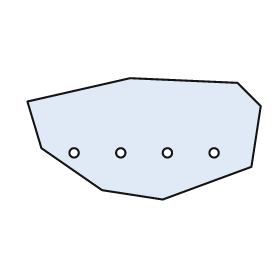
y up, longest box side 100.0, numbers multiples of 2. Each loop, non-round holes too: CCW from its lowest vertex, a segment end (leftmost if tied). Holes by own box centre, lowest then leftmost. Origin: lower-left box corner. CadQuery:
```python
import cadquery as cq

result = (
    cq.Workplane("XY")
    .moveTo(58.0, 0.0)
    .lineTo(96.0, 14.0)
    .lineTo(100.0, 40.0)
    .lineTo(90.0, 50.0)
    .lineTo(44.0, 52.0)
    .lineTo(0.0, 42.0)
    .lineTo(6.0, 22.0)
    .lineTo(32.0, 4.0)
    .close()
    .moveTo(20.0, 20.0)
    .circle(2.0)
    .moveTo(40.0, 20.0)
    .circle(2.0)
    .moveTo(60.0, 20.0)
    .circle(2.0)
    .moveTo(80.0, 20.0)
    .circle(2.0)
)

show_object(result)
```